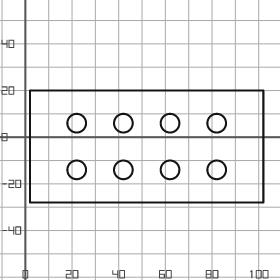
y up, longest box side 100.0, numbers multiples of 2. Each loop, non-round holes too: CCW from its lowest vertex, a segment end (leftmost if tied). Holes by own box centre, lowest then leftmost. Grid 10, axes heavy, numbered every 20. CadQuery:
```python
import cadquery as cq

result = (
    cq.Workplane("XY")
    .moveTo(2.0, -28.0)
    .lineTo(102.0, -28.0)
    .lineTo(102.0, 20.0)
    .lineTo(2.0, 20.0)
    .close()
    .moveTo(22.0, -14.0)
    .circle(4.0)
    .moveTo(42.0, -14.0)
    .circle(4.0)
    .moveTo(62.0, -14.0)
    .circle(4.0)
    .moveTo(82.0, -14.0)
    .circle(4.0)
    .moveTo(22.0, 6.0)
    .circle(4.0)
    .moveTo(42.0, 6.0)
    .circle(4.0)
    .moveTo(62.0, 6.0)
    .circle(4.0)
    .moveTo(82.0, 6.0)
    .circle(4.0)
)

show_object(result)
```